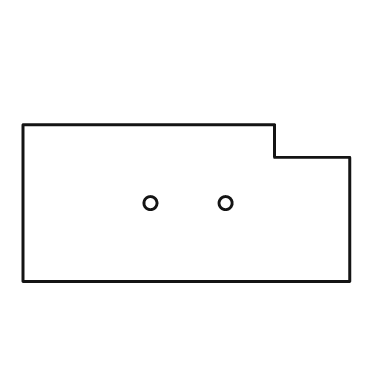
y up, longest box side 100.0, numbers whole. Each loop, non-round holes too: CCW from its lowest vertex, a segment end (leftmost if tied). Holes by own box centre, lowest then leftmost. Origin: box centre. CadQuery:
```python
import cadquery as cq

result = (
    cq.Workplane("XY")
    .moveTo(-50.0, -24.0)
    .lineTo(50.0, -24.0)
    .lineTo(50.0, 14.0)
    .lineTo(27.0, 14.0)
    .lineTo(27.0, 24.0)
    .lineTo(-50.0, 24.0)
    .close()
    .moveTo(-11.0, 0.0)
    .circle(2.0)
    .moveTo(12.0, 0.0)
    .circle(2.0)
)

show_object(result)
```